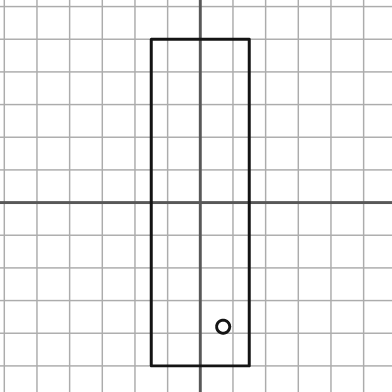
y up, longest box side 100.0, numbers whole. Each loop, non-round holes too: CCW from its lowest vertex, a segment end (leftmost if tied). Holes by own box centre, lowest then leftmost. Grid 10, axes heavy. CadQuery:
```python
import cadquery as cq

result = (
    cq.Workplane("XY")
    .moveTo(-15.0, -50.0)
    .lineTo(15.0, -50.0)
    .lineTo(15.0, 50.0)
    .lineTo(-15.0, 50.0)
    .close()
    .moveTo(7.0, -38.0)
    .circle(2.0)
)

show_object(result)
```